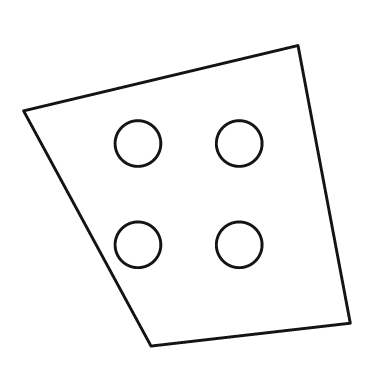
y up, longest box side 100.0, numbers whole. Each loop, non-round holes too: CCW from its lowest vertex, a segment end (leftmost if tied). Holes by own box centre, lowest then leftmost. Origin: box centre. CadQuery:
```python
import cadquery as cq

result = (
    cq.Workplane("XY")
    .moveTo(-11.0, -46.0)
    .lineTo(50.0, -39.0)
    .lineTo(34.0, 46.0)
    .lineTo(-50.0, 26.0)
    .close()
    .moveTo(-15.0, -15.0)
    .circle(7.0)
    .moveTo(16.0, -15.0)
    .circle(7.0)
    .moveTo(-15.0, 16.0)
    .circle(7.0)
    .moveTo(16.0, 16.0)
    .circle(7.0)
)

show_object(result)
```